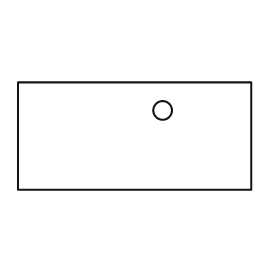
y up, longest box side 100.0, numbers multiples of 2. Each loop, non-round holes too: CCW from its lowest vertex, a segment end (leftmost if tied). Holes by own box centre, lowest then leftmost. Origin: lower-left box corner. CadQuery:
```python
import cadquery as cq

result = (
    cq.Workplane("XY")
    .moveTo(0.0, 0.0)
    .lineTo(100.0, 0.0)
    .lineTo(100.0, 46.0)
    .lineTo(0.0, 46.0)
    .close()
    .moveTo(62.0, 34.0)
    .circle(4.0)
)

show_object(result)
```